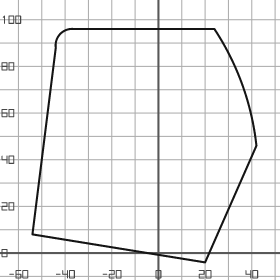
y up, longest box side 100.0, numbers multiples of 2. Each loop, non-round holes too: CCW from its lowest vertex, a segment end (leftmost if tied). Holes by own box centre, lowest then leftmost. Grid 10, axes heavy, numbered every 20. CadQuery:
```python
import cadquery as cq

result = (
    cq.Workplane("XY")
    .moveTo(20.0, -4.0)
    .lineTo(42.0, 46.0)
    .threePointArc((36.0, 72.0), (24.0, 96.0))
    .lineTo(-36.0, 96.0)
    .threePointArc((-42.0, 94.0), (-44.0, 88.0))
    .lineTo(-54.0, 8.0)
    .close()
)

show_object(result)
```